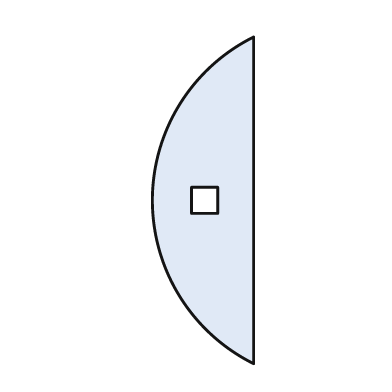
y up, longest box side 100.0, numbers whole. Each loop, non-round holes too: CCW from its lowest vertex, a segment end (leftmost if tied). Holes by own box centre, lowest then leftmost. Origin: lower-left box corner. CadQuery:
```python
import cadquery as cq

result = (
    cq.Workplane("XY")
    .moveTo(31.0, 0.0)
    .lineTo(31.0, 100.0)
    .threePointArc((0.0, 50.0), (31.0, 0.0))
    .close()
    .moveTo(12.0, 46.0)
    .lineTo(20.0, 46.0)
    .lineTo(20.0, 54.0)
    .lineTo(12.0, 54.0)
    .close()
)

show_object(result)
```